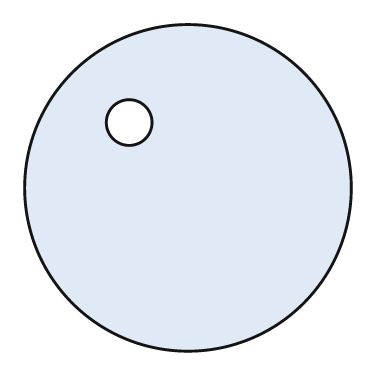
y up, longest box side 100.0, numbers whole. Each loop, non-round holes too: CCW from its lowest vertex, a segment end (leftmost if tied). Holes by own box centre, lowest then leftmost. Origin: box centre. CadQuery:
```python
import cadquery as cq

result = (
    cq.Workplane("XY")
    .moveTo(0.0, 0.0)
    .circle(50.0)
    .moveTo(-18.0, 20.0)
    .circle(7.0)
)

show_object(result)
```